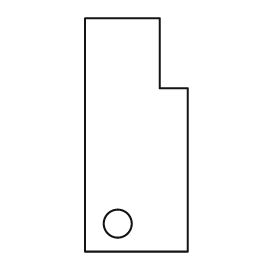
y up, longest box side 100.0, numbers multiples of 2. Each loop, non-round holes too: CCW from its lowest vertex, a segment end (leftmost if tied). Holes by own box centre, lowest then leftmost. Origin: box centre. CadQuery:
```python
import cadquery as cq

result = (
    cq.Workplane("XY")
    .moveTo(-22.0, -50.0)
    .lineTo(22.0, -50.0)
    .lineTo(22.0, 20.0)
    .lineTo(10.0, 20.0)
    .lineTo(10.0, 50.0)
    .lineTo(-22.0, 50.0)
    .close()
    .moveTo(-8.0, -38.0)
    .circle(6.0)
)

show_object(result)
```